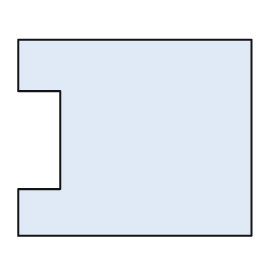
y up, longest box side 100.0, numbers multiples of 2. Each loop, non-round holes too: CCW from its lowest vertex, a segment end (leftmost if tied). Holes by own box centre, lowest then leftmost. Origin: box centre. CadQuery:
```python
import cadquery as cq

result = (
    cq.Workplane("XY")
    .moveTo(-50.0, -42.0)
    .lineTo(50.0, -42.0)
    .lineTo(50.0, 42.0)
    .lineTo(-50.0, 42.0)
    .lineTo(-50.0, 20.0)
    .lineTo(-32.0, 20.0)
    .lineTo(-32.0, -22.0)
    .lineTo(-50.0, -22.0)
    .close()
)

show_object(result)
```